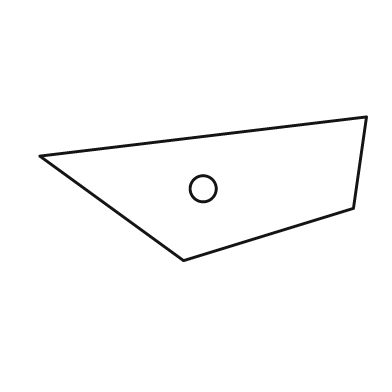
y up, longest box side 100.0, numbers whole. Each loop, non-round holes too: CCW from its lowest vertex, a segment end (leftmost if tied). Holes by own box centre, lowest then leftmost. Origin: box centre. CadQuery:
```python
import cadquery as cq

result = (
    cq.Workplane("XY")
    .moveTo(-6.0, -22.0)
    .lineTo(46.0, -6.0)
    .lineTo(50.0, 22.0)
    .lineTo(-50.0, 10.0)
    .close()
    .moveTo(0.0, 0.0)
    .circle(4.0)
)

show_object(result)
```